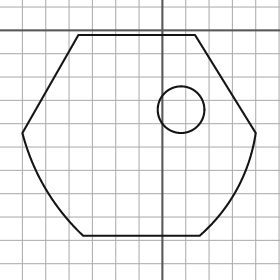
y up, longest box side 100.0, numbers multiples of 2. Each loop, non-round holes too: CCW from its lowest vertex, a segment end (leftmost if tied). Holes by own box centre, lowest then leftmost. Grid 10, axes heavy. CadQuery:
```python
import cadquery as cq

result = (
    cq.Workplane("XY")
    .moveTo(-34.0, -88.0)
    .lineTo(16.0, -88.0)
    .threePointArc((32.0, -68.0), (40.0, -44.0))
    .lineTo(14.0, -2.0)
    .lineTo(-36.0, -2.0)
    .lineTo(-60.0, -44.0)
    .threePointArc((-50.0, -68.0), (-34.0, -88.0))
    .close()
    .moveTo(8.0, -34.0)
    .circle(10.0)
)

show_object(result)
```